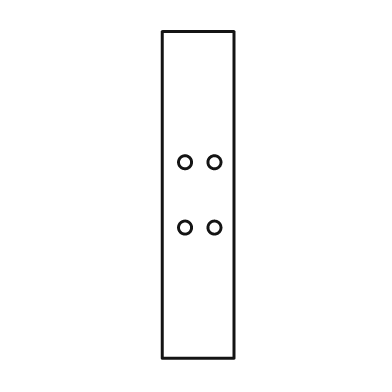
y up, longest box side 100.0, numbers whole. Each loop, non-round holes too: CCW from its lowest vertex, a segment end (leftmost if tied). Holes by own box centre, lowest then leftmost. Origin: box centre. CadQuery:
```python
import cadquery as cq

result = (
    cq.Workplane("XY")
    .moveTo(-11.0, -50.0)
    .lineTo(11.0, -50.0)
    .lineTo(11.0, 50.0)
    .lineTo(-11.0, 50.0)
    .close()
    .moveTo(-4.0, -10.0)
    .circle(2.0)
    .moveTo(5.0, -10.0)
    .circle(2.0)
    .moveTo(-4.0, 10.0)
    .circle(2.0)
    .moveTo(5.0, 10.0)
    .circle(2.0)
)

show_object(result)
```